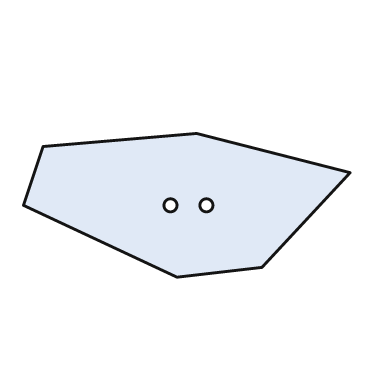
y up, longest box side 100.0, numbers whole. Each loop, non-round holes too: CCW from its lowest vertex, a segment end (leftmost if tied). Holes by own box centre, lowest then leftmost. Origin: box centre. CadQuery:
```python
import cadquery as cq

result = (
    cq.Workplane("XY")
    .moveTo(-3.0, -22.0)
    .lineTo(23.0, -19.0)
    .lineTo(50.0, 10.0)
    .lineTo(3.0, 22.0)
    .lineTo(-44.0, 18.0)
    .lineTo(-50.0, 0.0)
    .close()
    .moveTo(-5.0, 0.0)
    .circle(2.0)
    .moveTo(6.0, 0.0)
    .circle(2.0)
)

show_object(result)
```